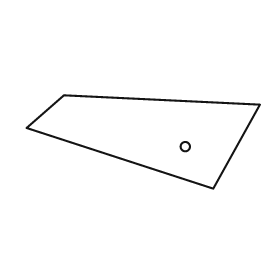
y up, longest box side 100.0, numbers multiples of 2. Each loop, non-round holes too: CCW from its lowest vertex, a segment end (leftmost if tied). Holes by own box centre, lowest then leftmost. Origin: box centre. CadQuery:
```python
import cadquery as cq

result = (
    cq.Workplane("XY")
    .moveTo(30.0, -20.0)
    .lineTo(50.0, 16.0)
    .lineTo(-34.0, 20.0)
    .lineTo(-50.0, 6.0)
    .close()
    .moveTo(18.0, -2.0)
    .circle(2.0)
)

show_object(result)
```